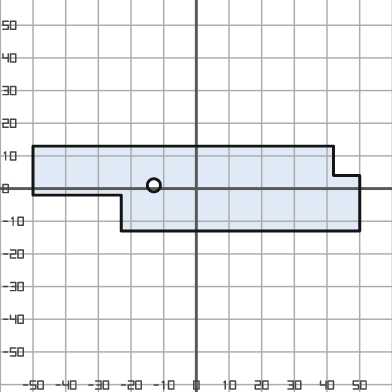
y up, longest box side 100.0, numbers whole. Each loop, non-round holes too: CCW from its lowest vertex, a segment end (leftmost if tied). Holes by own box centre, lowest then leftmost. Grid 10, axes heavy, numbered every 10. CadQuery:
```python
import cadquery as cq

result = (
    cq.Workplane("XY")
    .moveTo(-23.0, -13.0)
    .lineTo(50.0, -13.0)
    .lineTo(50.0, 4.0)
    .lineTo(42.0, 4.0)
    .lineTo(42.0, 13.0)
    .lineTo(-50.0, 13.0)
    .lineTo(-50.0, -2.0)
    .lineTo(-23.0, -2.0)
    .close()
    .moveTo(-13.0, 1.0)
    .circle(2.0)
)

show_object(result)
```